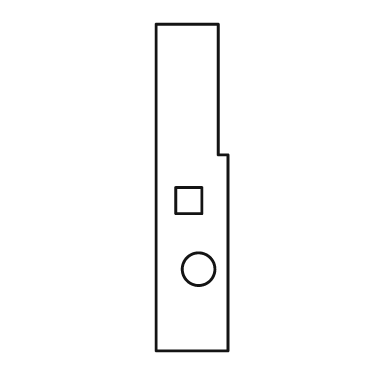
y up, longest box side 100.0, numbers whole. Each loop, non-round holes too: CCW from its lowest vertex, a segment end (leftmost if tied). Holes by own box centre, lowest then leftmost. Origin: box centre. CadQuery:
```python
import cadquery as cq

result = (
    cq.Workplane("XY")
    .moveTo(-11.0, -50.0)
    .lineTo(11.0, -50.0)
    .lineTo(11.0, 10.0)
    .lineTo(8.0, 10.0)
    .lineTo(8.0, 50.0)
    .lineTo(-11.0, 50.0)
    .close()
    .moveTo(2.0, -25.0)
    .circle(5.0)
    .moveTo(-5.0, -8.0)
    .lineTo(3.0, -8.0)
    .lineTo(3.0, 0.0)
    .lineTo(-5.0, 0.0)
    .close()
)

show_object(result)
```